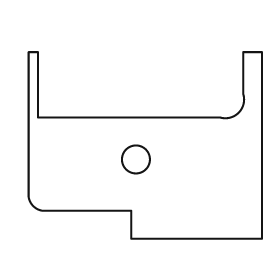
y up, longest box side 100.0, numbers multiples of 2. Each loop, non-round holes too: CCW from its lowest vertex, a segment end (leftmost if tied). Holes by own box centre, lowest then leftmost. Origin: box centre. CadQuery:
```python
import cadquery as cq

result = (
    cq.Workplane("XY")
    .moveTo(-6.0, -40.0)
    .lineTo(50.0, -40.0)
    .lineTo(50.0, 40.0)
    .lineTo(42.0, 40.0)
    .lineTo(42.0, 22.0)
    .threePointArc((40.0, 14.0), (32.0, 12.0))
    .lineTo(-46.0, 12.0)
    .lineTo(-46.0, 40.0)
    .lineTo(-50.0, 40.0)
    .lineTo(-50.0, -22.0)
    .threePointArc((-48.0, -26.0), (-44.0, -28.0))
    .lineTo(-6.0, -28.0)
    .close()
    .moveTo(-4.0, -6.0)
    .circle(6.0)
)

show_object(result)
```